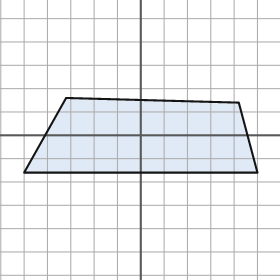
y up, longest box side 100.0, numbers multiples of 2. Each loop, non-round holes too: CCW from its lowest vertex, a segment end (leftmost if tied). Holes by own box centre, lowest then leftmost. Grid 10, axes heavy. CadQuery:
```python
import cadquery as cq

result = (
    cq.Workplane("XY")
    .moveTo(-50.0, -16.0)
    .lineTo(50.0, -16.0)
    .lineTo(42.0, 14.0)
    .lineTo(-32.0, 16.0)
    .close()
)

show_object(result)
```